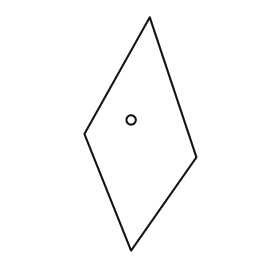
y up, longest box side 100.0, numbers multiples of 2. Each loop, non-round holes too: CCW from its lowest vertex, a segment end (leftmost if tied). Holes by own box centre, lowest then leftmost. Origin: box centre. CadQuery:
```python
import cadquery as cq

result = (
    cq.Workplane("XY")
    .moveTo(-4.0, -50.0)
    .lineTo(24.0, -10.0)
    .lineTo(4.0, 50.0)
    .lineTo(-24.0, 0.0)
    .close()
    .moveTo(-4.0, 6.0)
    .circle(2.0)
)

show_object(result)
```